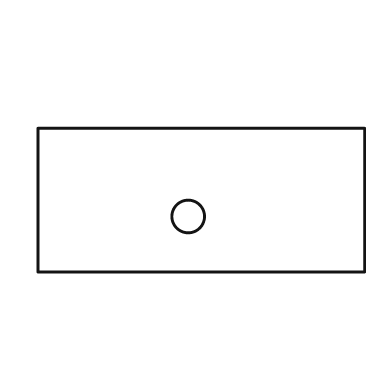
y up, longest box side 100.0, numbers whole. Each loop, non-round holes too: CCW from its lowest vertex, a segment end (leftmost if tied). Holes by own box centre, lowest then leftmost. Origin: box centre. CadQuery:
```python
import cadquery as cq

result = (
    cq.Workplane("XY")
    .moveTo(-50.0, -22.0)
    .lineTo(50.0, -22.0)
    .lineTo(50.0, 22.0)
    .lineTo(-50.0, 22.0)
    .close()
    .moveTo(-4.0, -5.0)
    .circle(5.0)
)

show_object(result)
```